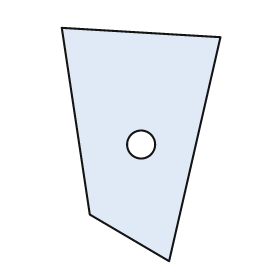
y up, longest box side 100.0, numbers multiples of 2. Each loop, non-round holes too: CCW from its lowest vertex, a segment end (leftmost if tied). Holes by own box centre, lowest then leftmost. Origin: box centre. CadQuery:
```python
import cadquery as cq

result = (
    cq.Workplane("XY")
    .moveTo(12.0, -50.0)
    .lineTo(34.0, 46.0)
    .lineTo(-34.0, 50.0)
    .lineTo(-22.0, -30.0)
    .close()
    .moveTo(0.0, 0.0)
    .circle(6.0)
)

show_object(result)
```